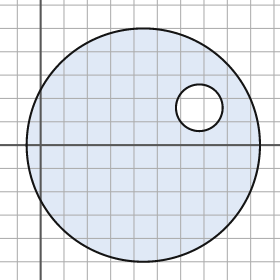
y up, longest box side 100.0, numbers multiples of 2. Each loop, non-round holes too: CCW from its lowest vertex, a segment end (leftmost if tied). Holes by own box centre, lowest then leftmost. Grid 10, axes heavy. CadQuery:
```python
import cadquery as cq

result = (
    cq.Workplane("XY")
    .moveTo(44.0, 0.0)
    .circle(50.0)
    .moveTo(68.0, 16.0)
    .circle(10.0)
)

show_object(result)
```